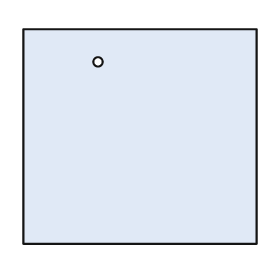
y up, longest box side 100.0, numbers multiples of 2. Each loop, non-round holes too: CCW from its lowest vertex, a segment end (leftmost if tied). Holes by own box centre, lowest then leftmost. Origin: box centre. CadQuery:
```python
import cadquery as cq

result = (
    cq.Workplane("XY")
    .moveTo(-50.0, -46.0)
    .lineTo(50.0, -46.0)
    .lineTo(50.0, 46.0)
    .lineTo(-50.0, 46.0)
    .close()
    .moveTo(-18.0, 32.0)
    .circle(2.0)
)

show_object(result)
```